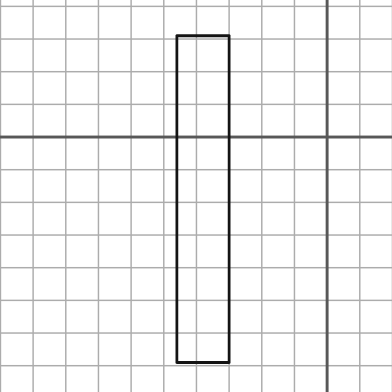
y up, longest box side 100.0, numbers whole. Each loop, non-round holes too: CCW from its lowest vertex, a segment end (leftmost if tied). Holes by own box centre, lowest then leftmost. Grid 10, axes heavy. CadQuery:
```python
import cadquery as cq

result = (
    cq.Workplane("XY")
    .moveTo(-46.0, -69.0)
    .lineTo(-30.0, -69.0)
    .lineTo(-30.0, 31.0)
    .lineTo(-46.0, 31.0)
    .close()
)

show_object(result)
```